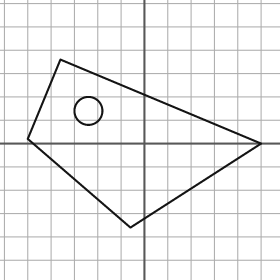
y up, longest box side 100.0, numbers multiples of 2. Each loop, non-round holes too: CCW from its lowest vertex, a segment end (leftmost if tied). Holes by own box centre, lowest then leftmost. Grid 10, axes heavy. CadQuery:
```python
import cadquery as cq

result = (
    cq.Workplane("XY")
    .moveTo(-6.0, -36.0)
    .lineTo(50.0, 0.0)
    .lineTo(-36.0, 36.0)
    .lineTo(-50.0, 2.0)
    .close()
    .moveTo(-24.0, 14.0)
    .circle(6.0)
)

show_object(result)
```